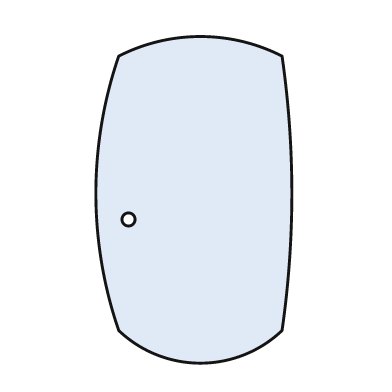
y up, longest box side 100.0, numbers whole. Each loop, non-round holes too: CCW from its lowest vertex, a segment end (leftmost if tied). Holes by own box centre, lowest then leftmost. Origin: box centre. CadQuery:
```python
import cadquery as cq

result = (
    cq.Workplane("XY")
    .moveTo(-23.0, -40.0)
    .threePointArc((2.0, -50.0), (27.0, -40.0))
    .threePointArc((30.0, 2.0), (27.0, 44.0))
    .threePointArc((2.0, 50.0), (-23.0, 44.0))
    .threePointArc((-30.0, 2.0), (-23.0, -40.0))
    .close()
    .moveTo(-20.0, -6.0)
    .circle(2.0)
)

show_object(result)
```